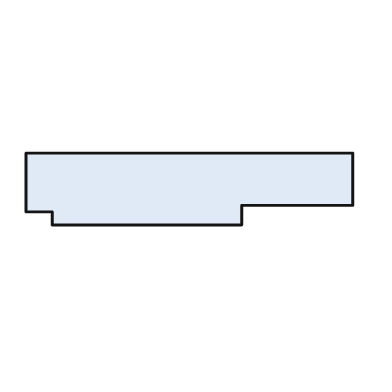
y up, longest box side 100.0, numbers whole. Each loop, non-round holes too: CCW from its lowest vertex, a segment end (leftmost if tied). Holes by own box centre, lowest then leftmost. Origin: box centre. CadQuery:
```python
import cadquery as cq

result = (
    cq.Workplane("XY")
    .moveTo(-42.0, -11.0)
    .lineTo(16.0, -11.0)
    .lineTo(16.0, -5.0)
    .lineTo(50.0, -5.0)
    .lineTo(50.0, 11.0)
    .lineTo(-50.0, 11.0)
    .lineTo(-50.0, -7.0)
    .lineTo(-42.0, -7.0)
    .close()
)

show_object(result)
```